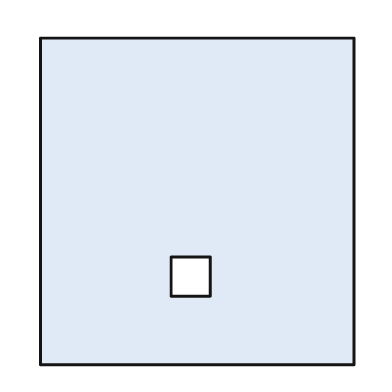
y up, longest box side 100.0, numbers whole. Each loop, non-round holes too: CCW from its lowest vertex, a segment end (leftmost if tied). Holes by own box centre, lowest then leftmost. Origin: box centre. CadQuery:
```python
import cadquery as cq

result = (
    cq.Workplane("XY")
    .moveTo(-48.0, -50.0)
    .lineTo(48.0, -50.0)
    .lineTo(48.0, 50.0)
    .lineTo(-48.0, 50.0)
    .close()
    .moveTo(-8.0, -29.0)
    .lineTo(4.0, -29.0)
    .lineTo(4.0, -17.0)
    .lineTo(-8.0, -17.0)
    .close()
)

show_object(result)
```